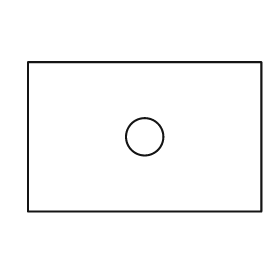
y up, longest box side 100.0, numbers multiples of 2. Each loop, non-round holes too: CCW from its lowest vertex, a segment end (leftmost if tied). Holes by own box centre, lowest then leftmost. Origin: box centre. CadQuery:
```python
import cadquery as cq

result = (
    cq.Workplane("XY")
    .moveTo(-50.0, -32.0)
    .lineTo(50.0, -32.0)
    .lineTo(50.0, 32.0)
    .lineTo(-50.0, 32.0)
    .close()
    .moveTo(0.0, 0.0)
    .circle(8.0)
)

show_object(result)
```